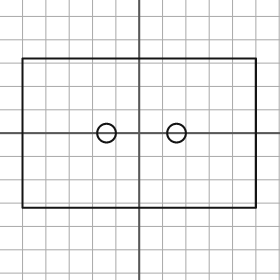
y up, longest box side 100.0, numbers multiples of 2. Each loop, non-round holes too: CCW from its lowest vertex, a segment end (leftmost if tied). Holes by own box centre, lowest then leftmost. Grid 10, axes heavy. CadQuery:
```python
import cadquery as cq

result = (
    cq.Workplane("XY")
    .moveTo(-50.0, -32.0)
    .lineTo(50.0, -32.0)
    .lineTo(50.0, 32.0)
    .lineTo(-50.0, 32.0)
    .close()
    .moveTo(-14.0, 0.0)
    .circle(4.0)
    .moveTo(16.0, 0.0)
    .circle(4.0)
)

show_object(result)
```